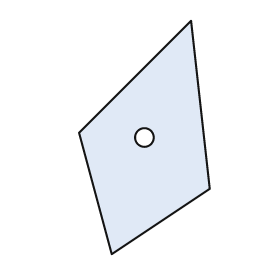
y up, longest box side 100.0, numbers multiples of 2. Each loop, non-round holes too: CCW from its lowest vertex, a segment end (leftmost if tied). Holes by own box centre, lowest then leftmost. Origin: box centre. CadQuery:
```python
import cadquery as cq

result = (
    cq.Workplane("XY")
    .moveTo(-14.0, -50.0)
    .lineTo(28.0, -22.0)
    .lineTo(20.0, 50.0)
    .lineTo(-28.0, 2.0)
    .close()
    .moveTo(0.0, 0.0)
    .circle(4.0)
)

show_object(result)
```